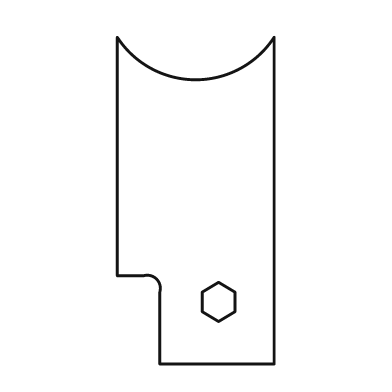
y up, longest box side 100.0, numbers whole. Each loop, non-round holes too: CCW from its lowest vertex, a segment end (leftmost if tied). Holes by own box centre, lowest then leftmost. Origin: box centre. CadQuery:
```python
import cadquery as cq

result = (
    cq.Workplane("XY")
    .moveTo(-11.0, -50.0)
    .lineTo(24.0, -50.0)
    .lineTo(24.0, 50.0)
    .threePointArc((0.0, 37.0), (-24.0, 50.0))
    .lineTo(-24.0, -23.0)
    .lineTo(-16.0, -23.0)
    .threePointArc((-12.0, -24.0), (-11.0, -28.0))
    .close()
    .moveTo(7.0, -37.0)
    .lineTo(12.0, -34.0)
    .lineTo(12.0, -28.0)
    .lineTo(7.0, -25.0)
    .lineTo(2.0, -28.0)
    .lineTo(2.0, -34.0)
    .close()
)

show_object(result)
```